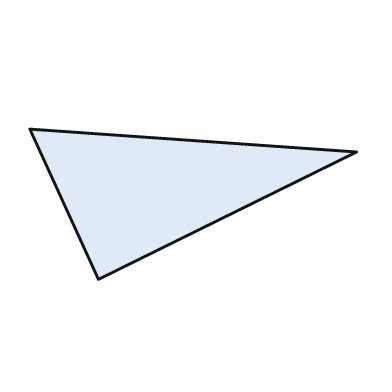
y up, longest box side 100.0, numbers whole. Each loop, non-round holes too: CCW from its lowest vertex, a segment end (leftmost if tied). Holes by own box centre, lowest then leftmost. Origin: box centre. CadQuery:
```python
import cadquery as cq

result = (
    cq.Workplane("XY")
    .moveTo(-29.0, -23.0)
    .lineTo(50.0, 16.0)
    .lineTo(-50.0, 23.0)
    .close()
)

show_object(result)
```